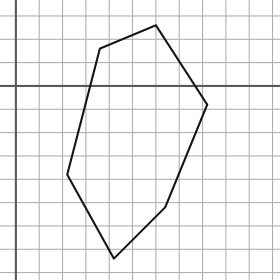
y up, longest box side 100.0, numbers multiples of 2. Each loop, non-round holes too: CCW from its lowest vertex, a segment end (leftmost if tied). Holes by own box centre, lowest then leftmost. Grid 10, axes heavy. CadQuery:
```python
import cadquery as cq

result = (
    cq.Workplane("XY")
    .moveTo(42.0, -74.0)
    .lineTo(64.0, -52.0)
    .lineTo(82.0, -8.0)
    .lineTo(60.0, 26.0)
    .lineTo(36.0, 16.0)
    .lineTo(22.0, -38.0)
    .close()
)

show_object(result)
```